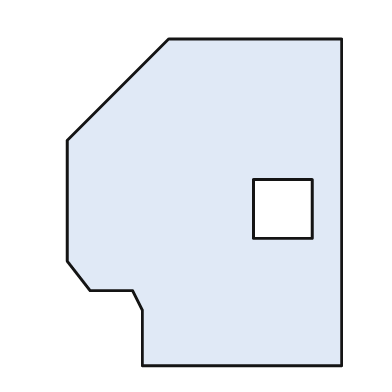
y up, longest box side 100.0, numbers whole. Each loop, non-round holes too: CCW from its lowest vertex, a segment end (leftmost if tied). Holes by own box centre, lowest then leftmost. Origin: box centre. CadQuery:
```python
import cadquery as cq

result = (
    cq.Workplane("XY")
    .moveTo(-19.0, -50.0)
    .lineTo(42.0, -50.0)
    .lineTo(42.0, 50.0)
    .lineTo(-11.0, 50.0)
    .lineTo(-42.0, 19.0)
    .lineTo(-42.0, -18.0)
    .lineTo(-35.0, -27.0)
    .lineTo(-22.0, -27.0)
    .lineTo(-19.0, -33.0)
    .close()
    .moveTo(15.0, -11.0)
    .lineTo(33.0, -11.0)
    .lineTo(33.0, 7.0)
    .lineTo(15.0, 7.0)
    .close()
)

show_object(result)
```